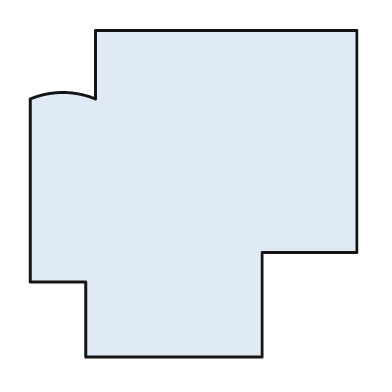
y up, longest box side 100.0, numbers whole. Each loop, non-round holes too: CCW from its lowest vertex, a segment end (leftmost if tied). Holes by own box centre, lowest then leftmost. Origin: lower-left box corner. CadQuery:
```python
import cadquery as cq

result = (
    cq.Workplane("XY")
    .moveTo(17.0, 0.0)
    .lineTo(71.0, 0.0)
    .lineTo(71.0, 32.0)
    .lineTo(100.0, 32.0)
    .lineTo(100.0, 100.0)
    .lineTo(20.0, 100.0)
    .lineTo(20.0, 79.0)
    .threePointArc((10.0, 81.0), (0.0, 79.0))
    .lineTo(0.0, 23.0)
    .lineTo(17.0, 23.0)
    .close()
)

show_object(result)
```